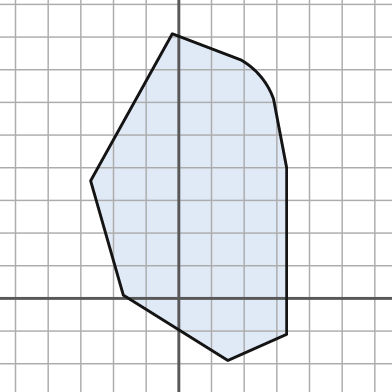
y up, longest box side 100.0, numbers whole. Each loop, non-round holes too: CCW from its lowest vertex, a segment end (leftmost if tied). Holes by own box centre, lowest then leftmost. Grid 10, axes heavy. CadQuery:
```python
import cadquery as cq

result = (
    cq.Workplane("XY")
    .moveTo(15.0, -19.0)
    .lineTo(33.0, -11.0)
    .lineTo(33.0, 40.0)
    .lineTo(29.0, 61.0)
    .threePointArc((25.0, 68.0), (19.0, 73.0))
    .lineTo(-2.0, 81.0)
    .lineTo(-27.0, 36.0)
    .lineTo(-17.0, 1.0)
    .close()
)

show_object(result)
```